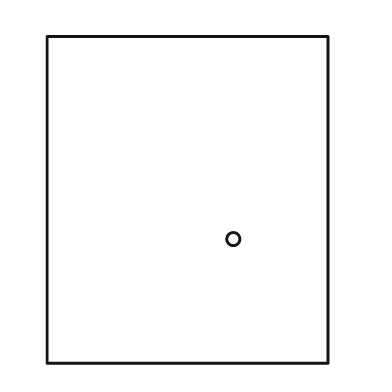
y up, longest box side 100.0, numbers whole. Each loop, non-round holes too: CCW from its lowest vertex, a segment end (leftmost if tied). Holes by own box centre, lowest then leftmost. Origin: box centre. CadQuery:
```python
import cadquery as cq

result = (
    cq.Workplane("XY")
    .moveTo(-43.0, -50.0)
    .lineTo(43.0, -50.0)
    .lineTo(43.0, 50.0)
    .lineTo(-43.0, 50.0)
    .close()
    .moveTo(14.0, -12.0)
    .circle(2.0)
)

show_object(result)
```